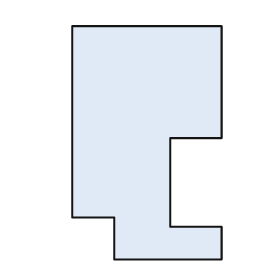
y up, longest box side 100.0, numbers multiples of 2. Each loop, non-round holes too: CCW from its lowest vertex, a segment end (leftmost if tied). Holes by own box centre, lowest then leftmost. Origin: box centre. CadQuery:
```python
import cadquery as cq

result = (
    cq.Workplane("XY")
    .moveTo(-14.0, -50.0)
    .lineTo(32.0, -50.0)
    .lineTo(32.0, -36.0)
    .lineTo(10.0, -36.0)
    .lineTo(10.0, 2.0)
    .lineTo(32.0, 2.0)
    .lineTo(32.0, 50.0)
    .lineTo(-32.0, 50.0)
    .lineTo(-32.0, -32.0)
    .lineTo(-14.0, -32.0)
    .close()
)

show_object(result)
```